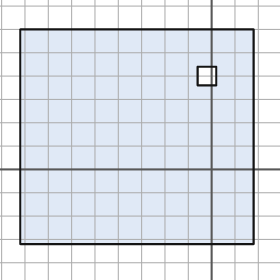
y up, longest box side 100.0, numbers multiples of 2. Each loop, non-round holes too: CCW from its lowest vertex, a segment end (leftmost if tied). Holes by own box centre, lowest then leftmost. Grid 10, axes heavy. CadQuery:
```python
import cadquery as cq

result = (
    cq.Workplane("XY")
    .moveTo(-82.0, -32.0)
    .lineTo(18.0, -32.0)
    .lineTo(18.0, 60.0)
    .lineTo(-82.0, 60.0)
    .close()
    .moveTo(-6.0, 36.0)
    .lineTo(2.0, 36.0)
    .lineTo(2.0, 44.0)
    .lineTo(-6.0, 44.0)
    .close()
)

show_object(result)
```